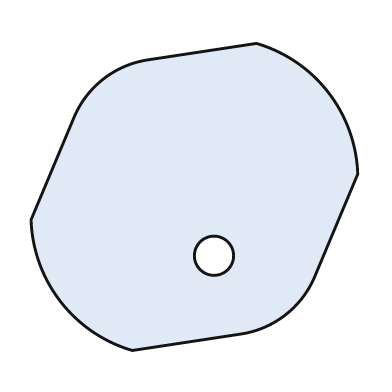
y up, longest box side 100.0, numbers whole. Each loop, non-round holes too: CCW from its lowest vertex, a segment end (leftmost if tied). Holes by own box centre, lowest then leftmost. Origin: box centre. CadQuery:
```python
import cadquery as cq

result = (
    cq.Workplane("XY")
    .moveTo(-19.0, -47.0)
    .lineTo(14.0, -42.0)
    .threePointArc((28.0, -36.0), (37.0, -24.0))
    .lineTo(50.0, 7.0)
    .threePointArc((41.0, 32.0), (19.0, 47.0))
    .lineTo(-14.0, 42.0)
    .threePointArc((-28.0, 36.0), (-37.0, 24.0))
    .lineTo(-50.0, -7.0)
    .threePointArc((-41.0, -32.0), (-19.0, -47.0))
    .close()
    .moveTo(6.0, -18.0)
    .circle(6.0)
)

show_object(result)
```